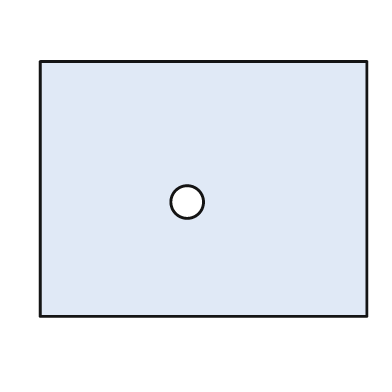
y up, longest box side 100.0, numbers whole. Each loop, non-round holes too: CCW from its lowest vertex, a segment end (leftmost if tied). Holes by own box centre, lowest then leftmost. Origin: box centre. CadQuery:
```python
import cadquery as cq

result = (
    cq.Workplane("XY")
    .moveTo(-50.0, -39.0)
    .lineTo(50.0, -39.0)
    .lineTo(50.0, 39.0)
    .lineTo(-50.0, 39.0)
    .close()
    .moveTo(-5.0, -4.0)
    .circle(5.0)
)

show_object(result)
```